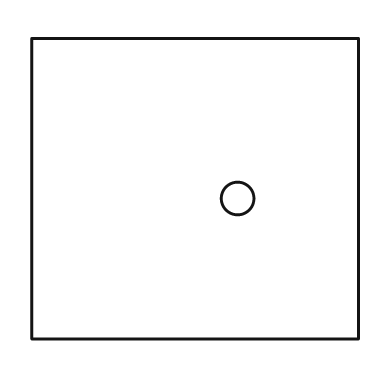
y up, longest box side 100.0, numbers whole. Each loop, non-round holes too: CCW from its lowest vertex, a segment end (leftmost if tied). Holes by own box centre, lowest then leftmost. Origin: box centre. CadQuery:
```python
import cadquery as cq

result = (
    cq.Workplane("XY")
    .moveTo(-50.0, -46.0)
    .lineTo(50.0, -46.0)
    .lineTo(50.0, 46.0)
    .lineTo(-50.0, 46.0)
    .close()
    .moveTo(13.0, -3.0)
    .circle(5.0)
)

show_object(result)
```